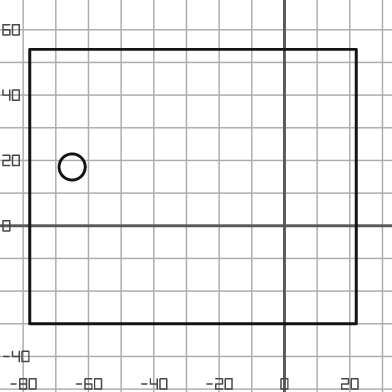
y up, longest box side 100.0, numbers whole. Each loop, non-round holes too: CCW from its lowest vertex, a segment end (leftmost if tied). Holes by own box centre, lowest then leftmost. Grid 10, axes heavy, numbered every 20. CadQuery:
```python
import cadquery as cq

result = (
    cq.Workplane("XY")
    .moveTo(-78.0, -30.0)
    .lineTo(22.0, -30.0)
    .lineTo(22.0, 54.0)
    .lineTo(-78.0, 54.0)
    .close()
    .moveTo(-65.0, 18.0)
    .circle(4.0)
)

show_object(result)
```